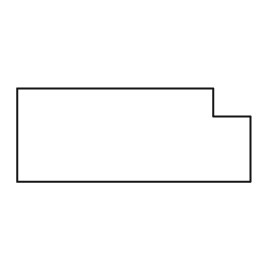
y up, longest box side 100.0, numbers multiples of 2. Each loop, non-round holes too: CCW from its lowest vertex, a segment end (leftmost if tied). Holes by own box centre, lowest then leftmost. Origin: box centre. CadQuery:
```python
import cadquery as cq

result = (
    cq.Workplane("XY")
    .moveTo(-50.0, -20.0)
    .lineTo(50.0, -20.0)
    .lineTo(50.0, 8.0)
    .lineTo(34.0, 8.0)
    .lineTo(34.0, 20.0)
    .lineTo(-50.0, 20.0)
    .close()
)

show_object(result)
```